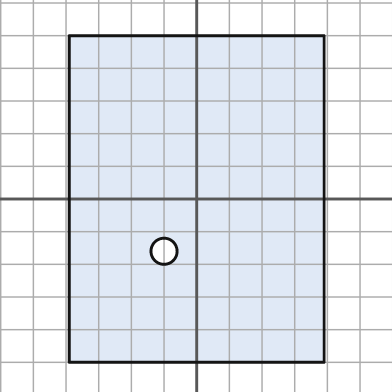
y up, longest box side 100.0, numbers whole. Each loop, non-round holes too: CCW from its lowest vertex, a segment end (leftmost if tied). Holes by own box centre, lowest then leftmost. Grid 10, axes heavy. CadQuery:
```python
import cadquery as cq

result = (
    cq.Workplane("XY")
    .moveTo(-39.0, -50.0)
    .lineTo(39.0, -50.0)
    .lineTo(39.0, 50.0)
    .lineTo(-39.0, 50.0)
    .close()
    .moveTo(-10.0, -16.0)
    .circle(4.0)
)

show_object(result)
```